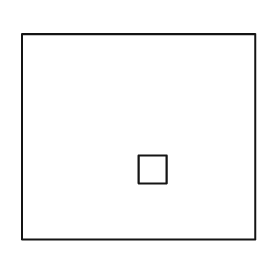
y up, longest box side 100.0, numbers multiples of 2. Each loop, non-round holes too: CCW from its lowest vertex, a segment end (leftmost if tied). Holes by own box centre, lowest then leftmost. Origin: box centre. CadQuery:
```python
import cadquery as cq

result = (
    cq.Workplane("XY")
    .moveTo(-50.0, -44.0)
    .lineTo(50.0, -44.0)
    .lineTo(50.0, 44.0)
    .lineTo(-50.0, 44.0)
    .close()
    .moveTo(0.0, -20.0)
    .lineTo(12.0, -20.0)
    .lineTo(12.0, -8.0)
    .lineTo(0.0, -8.0)
    .close()
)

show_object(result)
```